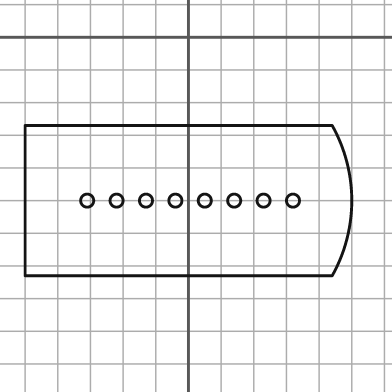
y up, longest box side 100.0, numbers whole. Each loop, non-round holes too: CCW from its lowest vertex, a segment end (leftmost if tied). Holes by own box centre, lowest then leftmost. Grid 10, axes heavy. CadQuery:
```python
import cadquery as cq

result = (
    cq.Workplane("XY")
    .moveTo(-50.0, -73.0)
    .lineTo(44.0, -73.0)
    .threePointArc((50.0, -50.0), (44.0, -27.0))
    .lineTo(-50.0, -27.0)
    .close()
    .moveTo(-31.0, -50.0)
    .circle(2.0)
    .moveTo(-22.0, -50.0)
    .circle(2.0)
    .moveTo(-13.0, -50.0)
    .circle(2.0)
    .moveTo(-4.0, -50.0)
    .circle(2.0)
    .moveTo(5.0, -50.0)
    .circle(2.0)
    .moveTo(14.0, -50.0)
    .circle(2.0)
    .moveTo(23.0, -50.0)
    .circle(2.0)
    .moveTo(32.0, -50.0)
    .circle(2.0)
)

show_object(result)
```